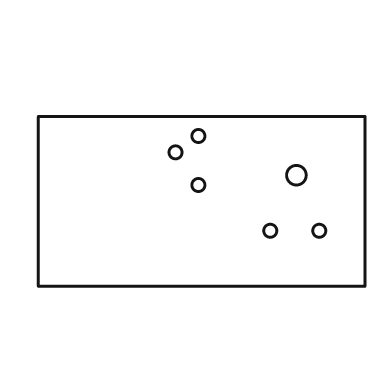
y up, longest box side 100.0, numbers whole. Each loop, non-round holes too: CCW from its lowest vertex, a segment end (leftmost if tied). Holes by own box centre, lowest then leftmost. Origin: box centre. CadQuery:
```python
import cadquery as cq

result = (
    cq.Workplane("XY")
    .moveTo(-50.0, -26.0)
    .lineTo(50.0, -26.0)
    .lineTo(50.0, 26.0)
    .lineTo(-50.0, 26.0)
    .close()
    .moveTo(21.0, -9.0)
    .circle(2.0)
    .moveTo(36.0, -9.0)
    .circle(2.0)
    .moveTo(-1.0, 5.0)
    .circle(2.0)
    .moveTo(29.0, 8.0)
    .circle(3.0)
    .moveTo(-8.0, 15.0)
    .circle(2.0)
    .moveTo(-1.0, 20.0)
    .circle(2.0)
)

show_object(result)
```